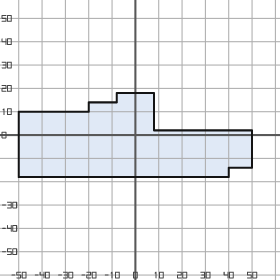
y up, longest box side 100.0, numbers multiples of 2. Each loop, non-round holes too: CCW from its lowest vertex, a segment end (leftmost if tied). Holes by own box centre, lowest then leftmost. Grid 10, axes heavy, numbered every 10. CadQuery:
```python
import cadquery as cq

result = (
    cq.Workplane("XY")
    .moveTo(-50.0, -18.0)
    .lineTo(40.0, -18.0)
    .lineTo(40.0, -14.0)
    .lineTo(50.0, -14.0)
    .lineTo(50.0, 2.0)
    .lineTo(8.0, 2.0)
    .lineTo(8.0, 18.0)
    .lineTo(-8.0, 18.0)
    .lineTo(-8.0, 14.0)
    .lineTo(-20.0, 14.0)
    .lineTo(-20.0, 10.0)
    .lineTo(-50.0, 10.0)
    .close()
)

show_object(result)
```